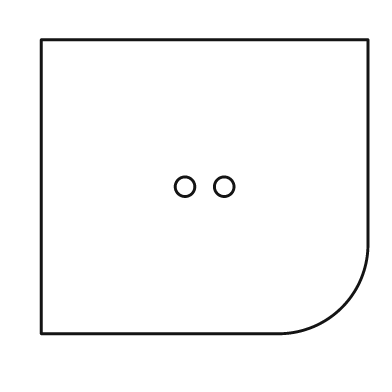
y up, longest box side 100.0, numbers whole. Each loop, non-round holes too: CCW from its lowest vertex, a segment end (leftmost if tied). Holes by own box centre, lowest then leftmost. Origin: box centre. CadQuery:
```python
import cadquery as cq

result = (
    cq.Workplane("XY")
    .moveTo(-50.0, -45.0)
    .lineTo(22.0, -45.0)
    .threePointArc((42.0, -37.0), (50.0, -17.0))
    .lineTo(50.0, 45.0)
    .lineTo(-50.0, 45.0)
    .close()
    .moveTo(-6.0, 0.0)
    .circle(3.0)
    .moveTo(6.0, 0.0)
    .circle(3.0)
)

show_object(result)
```